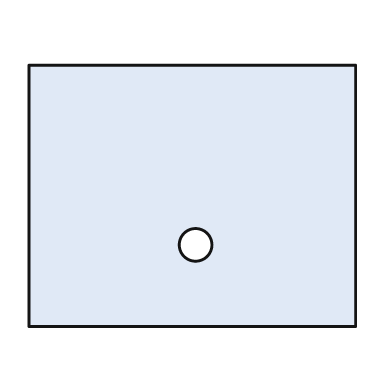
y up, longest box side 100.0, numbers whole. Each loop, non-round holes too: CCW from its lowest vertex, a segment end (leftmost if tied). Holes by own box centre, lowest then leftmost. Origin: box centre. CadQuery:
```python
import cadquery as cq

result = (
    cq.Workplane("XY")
    .moveTo(-50.0, -40.0)
    .lineTo(50.0, -40.0)
    .lineTo(50.0, 40.0)
    .lineTo(-50.0, 40.0)
    .close()
    .moveTo(1.0, -15.0)
    .circle(5.0)
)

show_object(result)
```